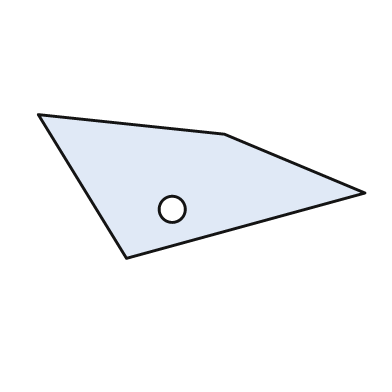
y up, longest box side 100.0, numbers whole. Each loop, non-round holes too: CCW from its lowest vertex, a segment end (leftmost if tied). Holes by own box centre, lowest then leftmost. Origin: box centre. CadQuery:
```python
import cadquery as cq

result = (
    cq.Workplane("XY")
    .moveTo(-23.0, -22.0)
    .lineTo(50.0, -2.0)
    .lineTo(7.0, 16.0)
    .lineTo(-50.0, 22.0)
    .close()
    .moveTo(-9.0, -7.0)
    .circle(4.0)
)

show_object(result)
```